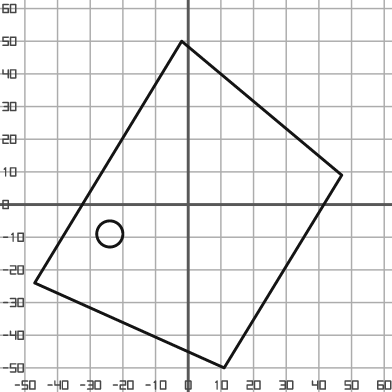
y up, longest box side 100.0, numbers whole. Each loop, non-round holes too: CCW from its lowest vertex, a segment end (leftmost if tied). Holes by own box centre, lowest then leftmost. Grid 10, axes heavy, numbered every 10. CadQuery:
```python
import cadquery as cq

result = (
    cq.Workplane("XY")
    .moveTo(11.0, -50.0)
    .lineTo(47.0, 9.0)
    .lineTo(-2.0, 50.0)
    .lineTo(-47.0, -24.0)
    .close()
    .moveTo(-24.0, -9.0)
    .circle(4.0)
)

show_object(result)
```